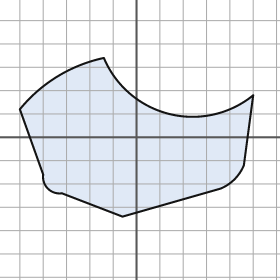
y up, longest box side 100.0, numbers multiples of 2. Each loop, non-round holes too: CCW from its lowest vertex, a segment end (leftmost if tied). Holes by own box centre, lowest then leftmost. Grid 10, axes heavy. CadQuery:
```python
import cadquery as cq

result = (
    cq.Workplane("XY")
    .moveTo(-6.0, -34.0)
    .lineTo(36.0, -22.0)
    .threePointArc((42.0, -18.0), (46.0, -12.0))
    .lineTo(50.0, 18.0)
    .threePointArc((14.0, 10.0), (-14.0, 34.0))
    .threePointArc((-34.0, 26.0), (-50.0, 12.0))
    .lineTo(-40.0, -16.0)
    .threePointArc((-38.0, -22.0), (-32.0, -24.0))
    .close()
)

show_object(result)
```